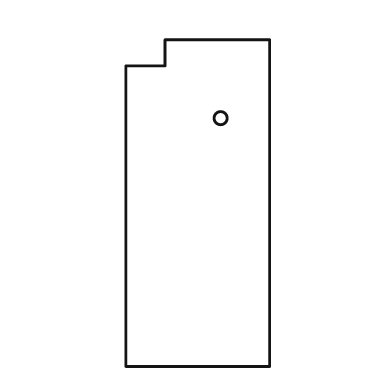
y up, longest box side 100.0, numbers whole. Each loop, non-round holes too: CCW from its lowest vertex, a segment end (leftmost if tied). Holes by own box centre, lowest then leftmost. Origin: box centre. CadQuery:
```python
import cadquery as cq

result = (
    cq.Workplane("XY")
    .moveTo(-22.0, -50.0)
    .lineTo(22.0, -50.0)
    .lineTo(22.0, 50.0)
    .lineTo(-10.0, 50.0)
    .lineTo(-10.0, 42.0)
    .lineTo(-22.0, 42.0)
    .close()
    .moveTo(7.0, 26.0)
    .circle(2.0)
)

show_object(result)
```